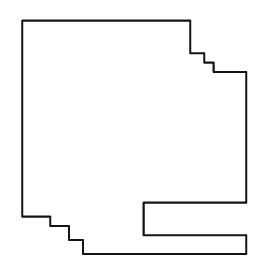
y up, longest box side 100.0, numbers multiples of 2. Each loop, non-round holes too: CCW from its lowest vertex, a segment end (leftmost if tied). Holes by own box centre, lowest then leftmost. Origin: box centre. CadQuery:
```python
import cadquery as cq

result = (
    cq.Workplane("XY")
    .moveTo(-22.0, -50.0)
    .lineTo(48.0, -50.0)
    .lineTo(48.0, -42.0)
    .lineTo(4.0, -42.0)
    .lineTo(4.0, -28.0)
    .lineTo(48.0, -28.0)
    .lineTo(48.0, 28.0)
    .lineTo(34.0, 28.0)
    .lineTo(34.0, 32.0)
    .lineTo(30.0, 32.0)
    .lineTo(30.0, 36.0)
    .lineTo(24.0, 36.0)
    .lineTo(24.0, 50.0)
    .lineTo(-48.0, 50.0)
    .lineTo(-48.0, -34.0)
    .lineTo(-36.0, -34.0)
    .lineTo(-36.0, -38.0)
    .lineTo(-28.0, -38.0)
    .lineTo(-28.0, -44.0)
    .lineTo(-22.0, -44.0)
    .close()
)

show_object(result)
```